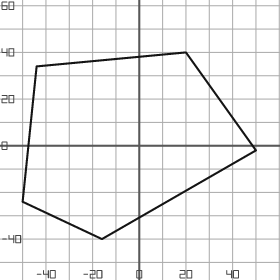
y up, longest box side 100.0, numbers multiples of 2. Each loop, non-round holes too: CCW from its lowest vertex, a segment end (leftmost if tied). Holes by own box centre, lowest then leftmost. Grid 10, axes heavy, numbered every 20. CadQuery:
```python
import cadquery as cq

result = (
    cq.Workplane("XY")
    .moveTo(-16.0, -40.0)
    .lineTo(50.0, -2.0)
    .lineTo(20.0, 40.0)
    .lineTo(-44.0, 34.0)
    .lineTo(-50.0, -24.0)
    .close()
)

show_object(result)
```